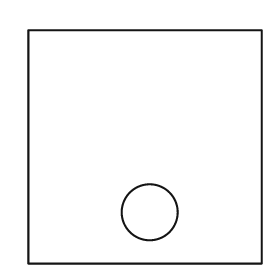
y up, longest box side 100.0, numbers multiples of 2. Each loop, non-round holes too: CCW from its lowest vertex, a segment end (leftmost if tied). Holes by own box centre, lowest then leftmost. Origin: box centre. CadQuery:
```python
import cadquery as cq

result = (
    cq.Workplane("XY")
    .moveTo(-50.0, -50.0)
    .lineTo(50.0, -50.0)
    .lineTo(50.0, 50.0)
    .lineTo(-50.0, 50.0)
    .close()
    .moveTo(2.0, -28.0)
    .circle(12.0)
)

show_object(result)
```